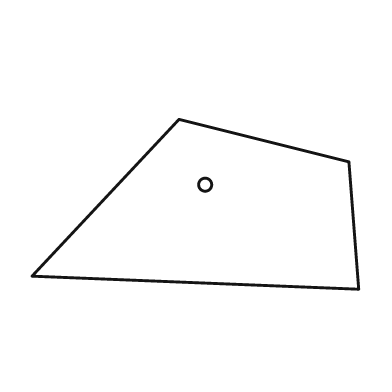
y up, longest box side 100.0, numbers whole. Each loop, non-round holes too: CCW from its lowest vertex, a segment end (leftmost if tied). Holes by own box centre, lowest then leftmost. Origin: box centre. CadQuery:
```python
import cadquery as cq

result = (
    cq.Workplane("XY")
    .moveTo(50.0, -26.0)
    .lineTo(47.0, 13.0)
    .lineTo(-5.0, 26.0)
    .lineTo(-50.0, -22.0)
    .close()
    .moveTo(3.0, 6.0)
    .circle(2.0)
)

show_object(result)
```